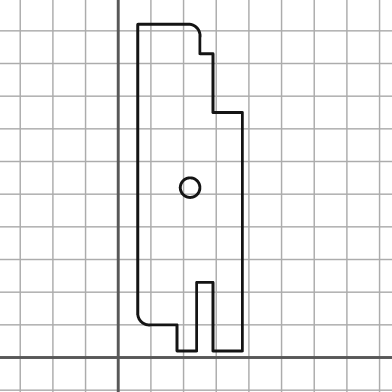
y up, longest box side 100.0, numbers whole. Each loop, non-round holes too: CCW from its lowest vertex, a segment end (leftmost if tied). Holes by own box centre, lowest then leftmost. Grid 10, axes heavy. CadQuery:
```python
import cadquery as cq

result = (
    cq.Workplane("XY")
    .moveTo(18.0, 2.0)
    .lineTo(24.0, 2.0)
    .lineTo(24.0, 23.0)
    .lineTo(29.0, 23.0)
    .lineTo(29.0, 2.0)
    .lineTo(38.0, 2.0)
    .lineTo(38.0, 75.0)
    .lineTo(29.0, 75.0)
    .lineTo(29.0, 93.0)
    .lineTo(25.0, 93.0)
    .lineTo(25.0, 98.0)
    .threePointArc((24.0, 101.0), (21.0, 102.0))
    .lineTo(6.0, 102.0)
    .lineTo(6.0, 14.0)
    .threePointArc((7.0, 11.0), (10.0, 10.0))
    .lineTo(18.0, 10.0)
    .close()
    .moveTo(22.0, 52.0)
    .circle(3.0)
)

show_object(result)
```